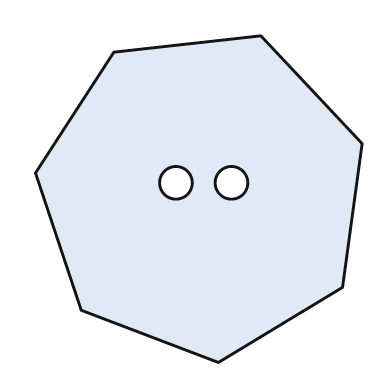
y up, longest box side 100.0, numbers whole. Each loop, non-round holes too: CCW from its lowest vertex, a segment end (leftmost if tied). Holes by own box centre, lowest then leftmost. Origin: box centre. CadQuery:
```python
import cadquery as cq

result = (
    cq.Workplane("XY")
    .moveTo(6.0, -50.0)
    .lineTo(44.0, -27.0)
    .lineTo(50.0, 17.0)
    .lineTo(19.0, 50.0)
    .lineTo(-26.0, 45.0)
    .lineTo(-50.0, 8.0)
    .lineTo(-36.0, -34.0)
    .close()
    .moveTo(-7.0, 5.0)
    .circle(5.0)
    .moveTo(10.0, 5.0)
    .circle(5.0)
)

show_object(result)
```